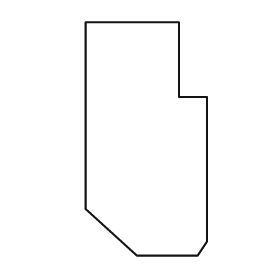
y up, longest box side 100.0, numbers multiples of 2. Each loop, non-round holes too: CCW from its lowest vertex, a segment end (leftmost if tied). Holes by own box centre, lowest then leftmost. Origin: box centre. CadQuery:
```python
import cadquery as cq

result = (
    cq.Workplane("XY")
    .moveTo(-4.0, -50.0)
    .lineTo(22.0, -50.0)
    .lineTo(26.0, -44.0)
    .lineTo(26.0, 18.0)
    .lineTo(14.0, 18.0)
    .lineTo(14.0, 50.0)
    .lineTo(-26.0, 50.0)
    .lineTo(-26.0, -30.0)
    .close()
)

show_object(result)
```